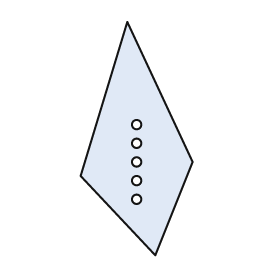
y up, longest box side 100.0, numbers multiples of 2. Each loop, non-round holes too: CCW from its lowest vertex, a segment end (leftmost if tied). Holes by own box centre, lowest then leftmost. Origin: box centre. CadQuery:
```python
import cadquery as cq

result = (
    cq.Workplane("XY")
    .moveTo(8.0, -50.0)
    .lineTo(24.0, -10.0)
    .lineTo(-4.0, 50.0)
    .lineTo(-24.0, -16.0)
    .close()
    .moveTo(0.0, -26.0)
    .circle(2.0)
    .moveTo(0.0, -18.0)
    .circle(2.0)
    .moveTo(0.0, -10.0)
    .circle(2.0)
    .moveTo(0.0, -2.0)
    .circle(2.0)
    .moveTo(0.0, 6.0)
    .circle(2.0)
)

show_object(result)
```